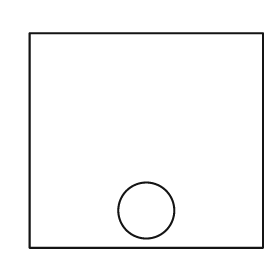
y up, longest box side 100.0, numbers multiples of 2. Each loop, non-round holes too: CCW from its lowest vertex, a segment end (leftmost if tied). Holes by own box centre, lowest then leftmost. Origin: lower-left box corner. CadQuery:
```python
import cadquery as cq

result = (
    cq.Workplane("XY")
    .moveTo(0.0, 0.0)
    .lineTo(100.0, 0.0)
    .lineTo(100.0, 92.0)
    .lineTo(0.0, 92.0)
    .close()
    .moveTo(50.0, 16.0)
    .circle(12.0)
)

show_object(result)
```